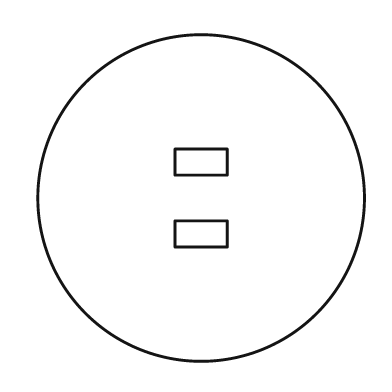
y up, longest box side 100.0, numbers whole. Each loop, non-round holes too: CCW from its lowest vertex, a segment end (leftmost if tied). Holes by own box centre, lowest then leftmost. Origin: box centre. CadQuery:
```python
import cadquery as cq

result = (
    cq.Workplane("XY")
    .moveTo(0.0, 0.0)
    .circle(50.0)
    .moveTo(-8.0, -15.0)
    .lineTo(8.0, -15.0)
    .lineTo(8.0, -7.0)
    .lineTo(-8.0, -7.0)
    .close()
    .moveTo(-8.0, 7.0)
    .lineTo(8.0, 7.0)
    .lineTo(8.0, 15.0)
    .lineTo(-8.0, 15.0)
    .close()
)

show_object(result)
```